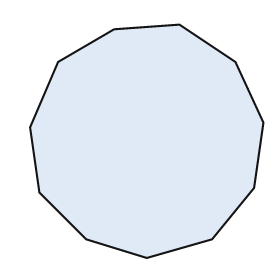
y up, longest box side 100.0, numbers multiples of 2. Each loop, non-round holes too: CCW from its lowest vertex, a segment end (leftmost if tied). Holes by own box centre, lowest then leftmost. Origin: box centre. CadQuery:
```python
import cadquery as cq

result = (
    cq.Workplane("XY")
    .moveTo(0.0, -50.0)
    .lineTo(28.0, -42.0)
    .lineTo(46.0, -20.0)
    .lineTo(50.0, 8.0)
    .lineTo(38.0, 34.0)
    .lineTo(14.0, 50.0)
    .lineTo(-14.0, 48.0)
    .lineTo(-38.0, 34.0)
    .lineTo(-50.0, 6.0)
    .lineTo(-46.0, -22.0)
    .lineTo(-26.0, -42.0)
    .close()
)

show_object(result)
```